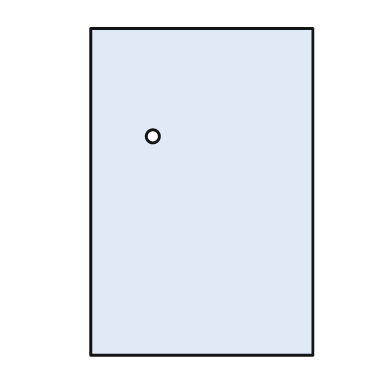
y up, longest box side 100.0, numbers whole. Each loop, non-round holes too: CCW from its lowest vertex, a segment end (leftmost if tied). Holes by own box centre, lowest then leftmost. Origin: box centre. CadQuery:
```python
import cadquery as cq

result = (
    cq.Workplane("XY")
    .moveTo(-34.0, -50.0)
    .lineTo(34.0, -50.0)
    .lineTo(34.0, 50.0)
    .lineTo(-34.0, 50.0)
    .close()
    .moveTo(-15.0, 17.0)
    .circle(2.0)
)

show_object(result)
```